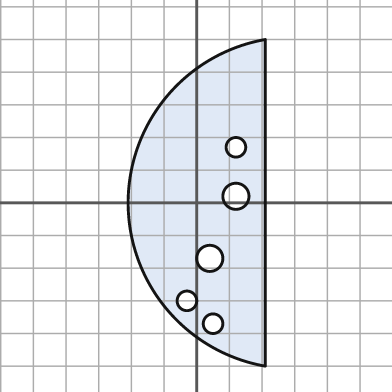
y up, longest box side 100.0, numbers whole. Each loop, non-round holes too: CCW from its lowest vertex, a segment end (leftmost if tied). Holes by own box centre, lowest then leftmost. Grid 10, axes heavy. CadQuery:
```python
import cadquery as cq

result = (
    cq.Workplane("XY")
    .moveTo(21.0, -50.0)
    .lineTo(21.0, 50.0)
    .threePointArc((-21.0, 0.0), (21.0, -50.0))
    .close()
    .moveTo(5.0, -37.0)
    .circle(3.0)
    .moveTo(-3.0, -30.0)
    .circle(3.0)
    .moveTo(4.0, -17.0)
    .circle(4.0)
    .moveTo(12.0, 2.0)
    .circle(4.0)
    .moveTo(12.0, 17.0)
    .circle(3.0)
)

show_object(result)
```